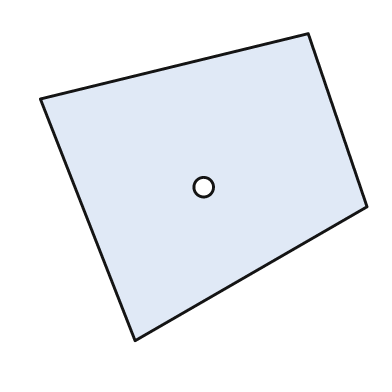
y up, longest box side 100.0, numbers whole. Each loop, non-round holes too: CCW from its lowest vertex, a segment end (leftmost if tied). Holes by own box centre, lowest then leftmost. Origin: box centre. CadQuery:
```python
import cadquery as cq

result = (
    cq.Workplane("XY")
    .moveTo(-21.0, -47.0)
    .lineTo(50.0, -6.0)
    .lineTo(32.0, 47.0)
    .lineTo(-50.0, 27.0)
    .close()
    .moveTo(0.0, 0.0)
    .circle(3.0)
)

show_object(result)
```